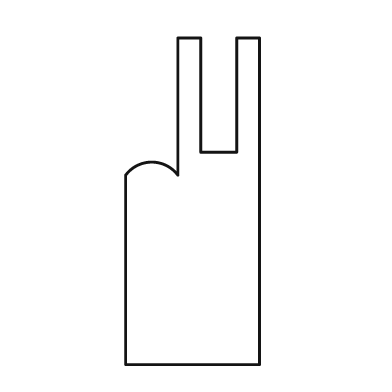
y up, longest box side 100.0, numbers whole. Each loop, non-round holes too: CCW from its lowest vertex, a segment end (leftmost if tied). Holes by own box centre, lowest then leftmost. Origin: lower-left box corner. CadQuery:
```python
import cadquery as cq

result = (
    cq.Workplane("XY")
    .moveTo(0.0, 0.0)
    .lineTo(41.0, 0.0)
    .lineTo(41.0, 100.0)
    .lineTo(34.0, 100.0)
    .lineTo(34.0, 65.0)
    .lineTo(23.0, 65.0)
    .lineTo(23.0, 100.0)
    .lineTo(16.0, 100.0)
    .lineTo(16.0, 58.0)
    .threePointArc((8.0, 62.0), (0.0, 58.0))
    .close()
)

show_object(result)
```